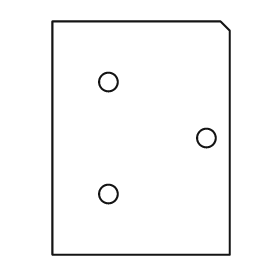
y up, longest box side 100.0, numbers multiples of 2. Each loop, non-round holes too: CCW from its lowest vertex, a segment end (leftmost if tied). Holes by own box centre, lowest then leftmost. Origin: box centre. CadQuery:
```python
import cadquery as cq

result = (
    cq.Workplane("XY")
    .moveTo(-38.0, -50.0)
    .lineTo(38.0, -50.0)
    .lineTo(38.0, 46.0)
    .lineTo(34.0, 50.0)
    .lineTo(-38.0, 50.0)
    .close()
    .moveTo(-14.0, -24.0)
    .circle(4.0)
    .moveTo(28.0, 0.0)
    .circle(4.0)
    .moveTo(-14.0, 24.0)
    .circle(4.0)
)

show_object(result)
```